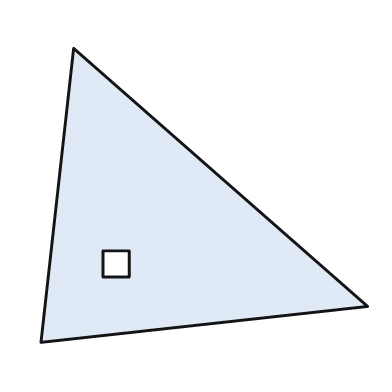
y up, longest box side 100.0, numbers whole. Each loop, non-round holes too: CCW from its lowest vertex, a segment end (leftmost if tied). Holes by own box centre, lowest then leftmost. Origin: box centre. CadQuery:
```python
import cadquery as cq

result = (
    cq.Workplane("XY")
    .moveTo(-50.0, -45.0)
    .lineTo(50.0, -34.0)
    .lineTo(-40.0, 45.0)
    .close()
    .moveTo(-31.0, -25.0)
    .lineTo(-23.0, -25.0)
    .lineTo(-23.0, -17.0)
    .lineTo(-31.0, -17.0)
    .close()
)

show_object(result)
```